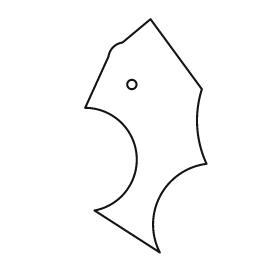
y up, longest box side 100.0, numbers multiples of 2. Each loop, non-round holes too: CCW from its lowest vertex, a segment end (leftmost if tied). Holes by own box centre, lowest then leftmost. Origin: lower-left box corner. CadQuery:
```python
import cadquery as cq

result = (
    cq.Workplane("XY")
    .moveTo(32.0, 0.0)
    .threePointArc((32.0, 24.0), (52.0, 38.0))
    .threePointArc((48.0, 54.0), (50.0, 70.0))
    .lineTo(28.0, 100.0)
    .lineTo(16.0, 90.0)
    .threePointArc((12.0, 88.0), (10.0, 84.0))
    .lineTo(0.0, 62.0)
    .threePointArc((22.0, 42.0), (4.0, 18.0))
    .close()
    .moveTo(20.0, 72.0)
    .circle(2.0)
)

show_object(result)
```